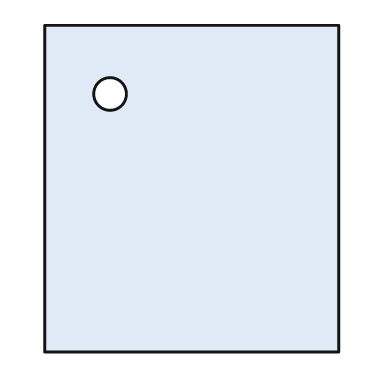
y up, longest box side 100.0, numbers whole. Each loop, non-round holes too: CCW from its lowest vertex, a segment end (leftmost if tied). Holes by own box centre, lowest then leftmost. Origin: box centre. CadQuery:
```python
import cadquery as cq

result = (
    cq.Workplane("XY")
    .moveTo(-45.0, -50.0)
    .lineTo(45.0, -50.0)
    .lineTo(45.0, 50.0)
    .lineTo(-45.0, 50.0)
    .close()
    .moveTo(-25.0, 29.0)
    .circle(5.0)
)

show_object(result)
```